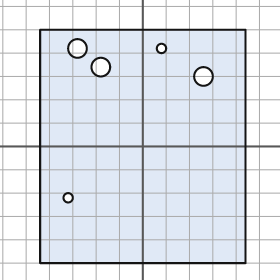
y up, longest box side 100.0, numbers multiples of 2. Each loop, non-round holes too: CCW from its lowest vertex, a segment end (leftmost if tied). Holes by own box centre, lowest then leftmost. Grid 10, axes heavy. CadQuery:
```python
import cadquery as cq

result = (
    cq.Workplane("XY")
    .moveTo(-44.0, -50.0)
    .lineTo(44.0, -50.0)
    .lineTo(44.0, 50.0)
    .lineTo(-44.0, 50.0)
    .close()
    .moveTo(-32.0, -22.0)
    .circle(2.0)
    .moveTo(26.0, 30.0)
    .circle(4.0)
    .moveTo(-18.0, 34.0)
    .circle(4.0)
    .moveTo(-28.0, 42.0)
    .circle(4.0)
    .moveTo(8.0, 42.0)
    .circle(2.0)
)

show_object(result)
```